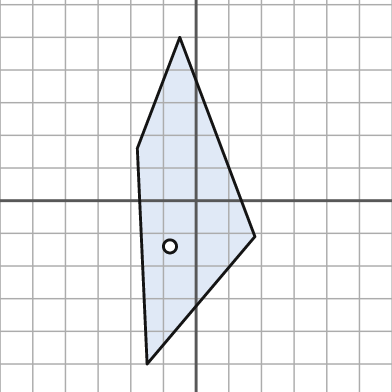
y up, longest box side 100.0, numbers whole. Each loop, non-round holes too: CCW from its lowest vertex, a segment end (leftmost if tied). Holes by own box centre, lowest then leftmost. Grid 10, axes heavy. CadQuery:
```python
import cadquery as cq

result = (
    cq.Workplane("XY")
    .moveTo(-15.0, -50.0)
    .lineTo(18.0, -11.0)
    .lineTo(-5.0, 50.0)
    .lineTo(-18.0, 16.0)
    .close()
    .moveTo(-8.0, -14.0)
    .circle(2.0)
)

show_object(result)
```